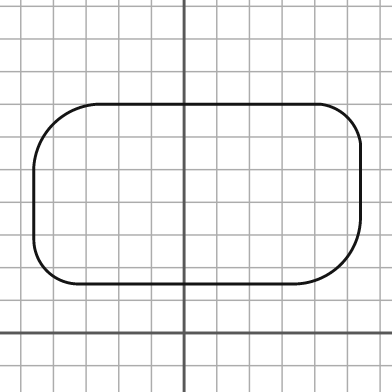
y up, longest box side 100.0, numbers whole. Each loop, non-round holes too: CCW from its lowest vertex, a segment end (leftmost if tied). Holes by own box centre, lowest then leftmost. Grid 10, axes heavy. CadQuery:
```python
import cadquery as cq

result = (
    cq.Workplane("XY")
    .moveTo(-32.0, 15.0)
    .lineTo(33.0, 15.0)
    .threePointArc((48.0, 21.0), (54.0, 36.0))
    .lineTo(54.0, 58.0)
    .threePointArc((50.0, 66.0), (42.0, 70.0))
    .lineTo(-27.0, 70.0)
    .threePointArc((-40.0, 64.0), (-46.0, 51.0))
    .lineTo(-46.0, 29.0)
    .threePointArc((-42.0, 19.0), (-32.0, 15.0))
    .close()
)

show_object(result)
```